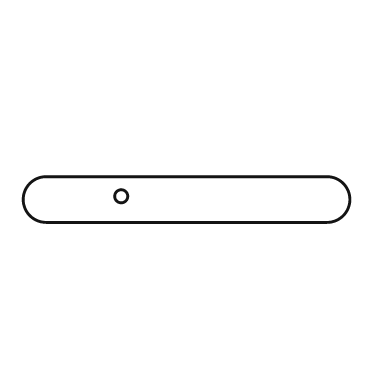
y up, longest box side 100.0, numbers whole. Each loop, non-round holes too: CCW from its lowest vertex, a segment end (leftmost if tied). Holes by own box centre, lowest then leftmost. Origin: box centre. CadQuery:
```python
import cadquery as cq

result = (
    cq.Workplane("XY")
    .moveTo(-43.0, -7.0)
    .lineTo(43.0, -7.0)
    .threePointArc((50.0, 0.0), (43.0, 7.0))
    .lineTo(-43.0, 7.0)
    .threePointArc((-50.0, 0.0), (-43.0, -7.0))
    .close()
    .moveTo(-20.0, 1.0)
    .circle(2.0)
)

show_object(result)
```